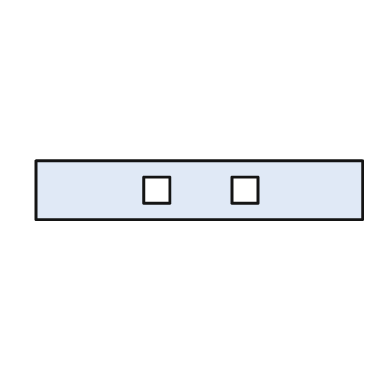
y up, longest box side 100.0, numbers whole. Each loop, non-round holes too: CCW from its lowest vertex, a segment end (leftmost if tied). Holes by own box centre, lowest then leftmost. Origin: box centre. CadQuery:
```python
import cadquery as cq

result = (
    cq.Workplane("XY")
    .moveTo(-50.0, -9.0)
    .lineTo(50.0, -9.0)
    .lineTo(50.0, 9.0)
    .lineTo(-50.0, 9.0)
    .close()
    .moveTo(-17.0, -4.0)
    .lineTo(-9.0, -4.0)
    .lineTo(-9.0, 4.0)
    .lineTo(-17.0, 4.0)
    .close()
    .moveTo(10.0, -4.0)
    .lineTo(18.0, -4.0)
    .lineTo(18.0, 4.0)
    .lineTo(10.0, 4.0)
    .close()
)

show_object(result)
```